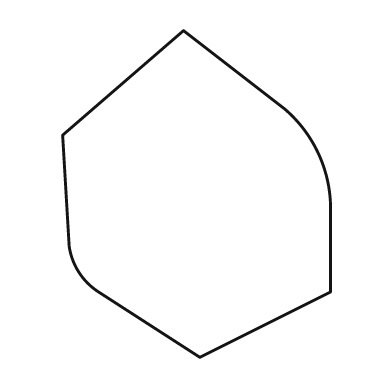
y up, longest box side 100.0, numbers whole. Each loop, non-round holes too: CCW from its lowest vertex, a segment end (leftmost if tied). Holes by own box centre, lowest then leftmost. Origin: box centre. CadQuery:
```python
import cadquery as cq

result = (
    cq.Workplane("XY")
    .moveTo(1.0, -50.0)
    .lineTo(41.0, -30.0)
    .lineTo(41.0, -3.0)
    .threePointArc((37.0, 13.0), (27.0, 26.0))
    .lineTo(-4.0, 50.0)
    .lineTo(-41.0, 18.0)
    .lineTo(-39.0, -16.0)
    .threePointArc((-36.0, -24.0), (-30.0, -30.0))
    .close()
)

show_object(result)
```